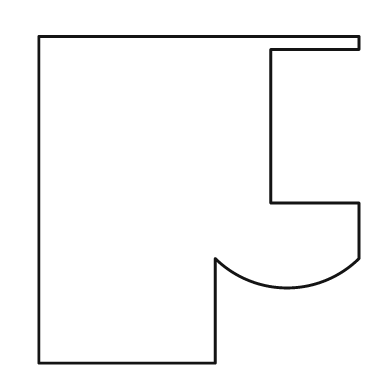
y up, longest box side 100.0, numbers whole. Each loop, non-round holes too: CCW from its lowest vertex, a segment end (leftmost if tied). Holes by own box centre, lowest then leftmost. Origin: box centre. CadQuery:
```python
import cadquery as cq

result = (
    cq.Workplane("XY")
    .moveTo(-49.0, -50.0)
    .lineTo(5.0, -50.0)
    .lineTo(5.0, -18.0)
    .threePointArc((27.0, -27.0), (49.0, -18.0))
    .lineTo(49.0, -1.0)
    .lineTo(22.0, -1.0)
    .lineTo(22.0, 46.0)
    .lineTo(49.0, 46.0)
    .lineTo(49.0, 50.0)
    .lineTo(-49.0, 50.0)
    .close()
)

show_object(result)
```